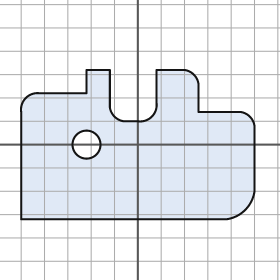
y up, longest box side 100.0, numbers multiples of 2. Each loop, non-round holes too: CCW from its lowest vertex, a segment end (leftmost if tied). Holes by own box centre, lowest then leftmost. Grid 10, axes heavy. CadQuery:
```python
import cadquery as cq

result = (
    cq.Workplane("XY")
    .moveTo(-50.0, -32.0)
    .lineTo(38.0, -32.0)
    .threePointArc((46.0, -28.0), (50.0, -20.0))
    .lineTo(50.0, 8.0)
    .threePointArc((48.0, 12.0), (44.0, 14.0))
    .lineTo(26.0, 14.0)
    .lineTo(26.0, 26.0)
    .threePointArc((24.0, 30.0), (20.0, 32.0))
    .lineTo(8.0, 32.0)
    .lineTo(8.0, 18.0)
    .threePointArc((6.0, 12.0), (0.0, 10.0))
    .lineTo(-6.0, 10.0)
    .threePointArc((-10.0, 12.0), (-12.0, 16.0))
    .lineTo(-12.0, 32.0)
    .lineTo(-22.0, 32.0)
    .lineTo(-22.0, 22.0)
    .lineTo(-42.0, 22.0)
    .threePointArc((-48.0, 20.0), (-50.0, 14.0))
    .close()
    .moveTo(-22.0, 0.0)
    .circle(6.0)
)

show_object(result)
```